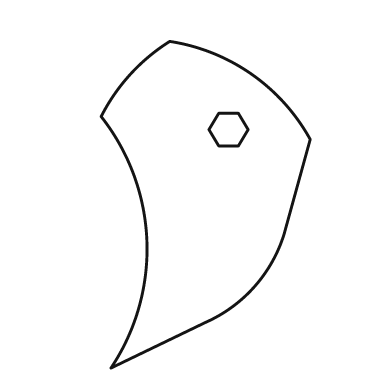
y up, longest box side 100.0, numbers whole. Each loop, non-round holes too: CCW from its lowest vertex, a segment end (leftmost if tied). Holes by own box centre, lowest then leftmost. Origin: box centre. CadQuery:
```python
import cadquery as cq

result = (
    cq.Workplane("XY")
    .moveTo(-29.0, -50.0)
    .lineTo(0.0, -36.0)
    .threePointArc((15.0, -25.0), (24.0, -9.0))
    .lineTo(32.0, 20.0)
    .threePointArc((14.0, 40.0), (-11.0, 50.0))
    .threePointArc((-23.0, 40.0), (-32.0, 27.0))
    .threePointArc((-18.0, -11.0), (-29.0, -50.0))
    .close()
    .moveTo(4.0, 18.0)
    .lineTo(10.0, 18.0)
    .lineTo(13.0, 23.0)
    .lineTo(10.0, 28.0)
    .lineTo(4.0, 28.0)
    .lineTo(1.0, 23.0)
    .close()
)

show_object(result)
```